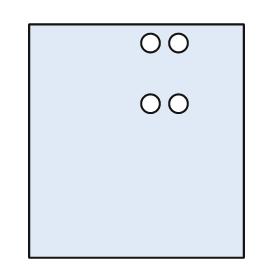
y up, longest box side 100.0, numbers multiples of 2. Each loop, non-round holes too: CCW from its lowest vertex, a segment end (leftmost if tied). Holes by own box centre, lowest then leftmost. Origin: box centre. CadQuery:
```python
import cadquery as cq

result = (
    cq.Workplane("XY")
    .moveTo(-46.0, -50.0)
    .lineTo(46.0, -50.0)
    .lineTo(46.0, 50.0)
    .lineTo(-46.0, 50.0)
    .close()
    .moveTo(6.0, 16.0)
    .circle(4.0)
    .moveTo(18.0, 16.0)
    .circle(4.0)
    .moveTo(6.0, 42.0)
    .circle(4.0)
    .moveTo(18.0, 42.0)
    .circle(4.0)
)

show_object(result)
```